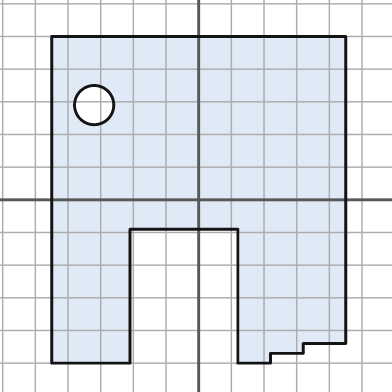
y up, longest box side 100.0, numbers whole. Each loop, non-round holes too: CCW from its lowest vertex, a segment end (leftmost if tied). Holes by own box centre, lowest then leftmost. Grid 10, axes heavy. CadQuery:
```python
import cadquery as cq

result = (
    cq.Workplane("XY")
    .moveTo(-45.0, -50.0)
    .lineTo(-21.0, -50.0)
    .lineTo(-21.0, -9.0)
    .lineTo(12.0, -9.0)
    .lineTo(12.0, -50.0)
    .lineTo(22.0, -50.0)
    .lineTo(22.0, -47.0)
    .lineTo(32.0, -47.0)
    .lineTo(32.0, -44.0)
    .lineTo(45.0, -44.0)
    .lineTo(45.0, 50.0)
    .lineTo(-45.0, 50.0)
    .close()
    .moveTo(-32.0, 29.0)
    .circle(6.0)
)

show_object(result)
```